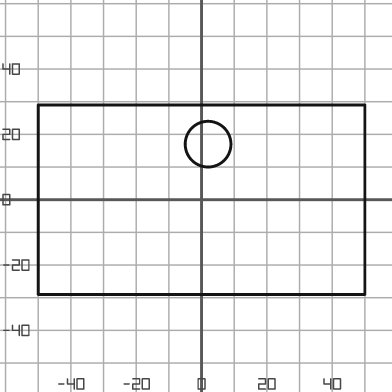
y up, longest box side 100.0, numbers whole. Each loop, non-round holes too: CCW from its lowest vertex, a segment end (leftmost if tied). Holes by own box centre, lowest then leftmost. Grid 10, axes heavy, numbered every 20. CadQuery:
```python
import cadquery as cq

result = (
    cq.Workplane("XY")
    .moveTo(-50.0, -29.0)
    .lineTo(50.0, -29.0)
    .lineTo(50.0, 29.0)
    .lineTo(-50.0, 29.0)
    .close()
    .moveTo(2.0, 17.0)
    .circle(7.0)
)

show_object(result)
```